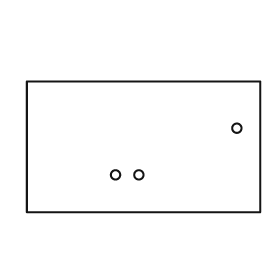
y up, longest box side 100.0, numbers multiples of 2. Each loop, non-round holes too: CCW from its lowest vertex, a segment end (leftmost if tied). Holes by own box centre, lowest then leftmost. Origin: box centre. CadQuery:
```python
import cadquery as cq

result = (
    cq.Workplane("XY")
    .moveTo(-50.0, -28.0)
    .lineTo(50.0, -28.0)
    .lineTo(50.0, 28.0)
    .lineTo(-50.0, 28.0)
    .close()
    .moveTo(-12.0, -12.0)
    .circle(2.0)
    .moveTo(-2.0, -12.0)
    .circle(2.0)
    .moveTo(40.0, 8.0)
    .circle(2.0)
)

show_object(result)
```